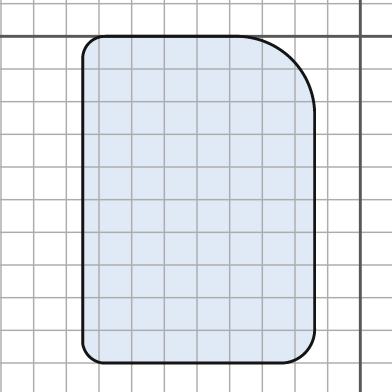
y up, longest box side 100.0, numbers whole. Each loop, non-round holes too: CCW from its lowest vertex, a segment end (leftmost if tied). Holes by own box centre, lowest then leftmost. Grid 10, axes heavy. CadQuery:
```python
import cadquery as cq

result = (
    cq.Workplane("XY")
    .moveTo(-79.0, -100.0)
    .lineTo(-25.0, -100.0)
    .threePointArc((-17.0, -97.0), (-14.0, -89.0))
    .lineTo(-14.0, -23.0)
    .threePointArc((-21.0, -7.0), (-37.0, 0.0))
    .lineTo(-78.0, 0.0)
    .threePointArc((-83.0, -2.0), (-85.0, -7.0))
    .lineTo(-85.0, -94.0)
    .threePointArc((-83.0, -98.0), (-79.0, -100.0))
    .close()
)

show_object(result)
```